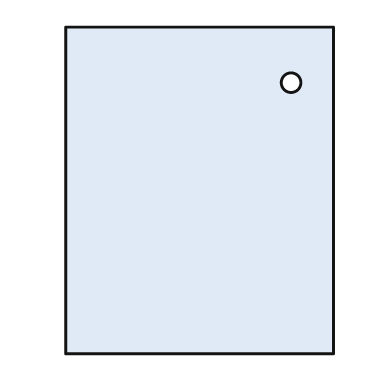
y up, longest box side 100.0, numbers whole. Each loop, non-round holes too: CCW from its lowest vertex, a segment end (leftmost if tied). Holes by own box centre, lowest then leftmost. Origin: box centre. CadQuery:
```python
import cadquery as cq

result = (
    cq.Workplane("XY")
    .moveTo(-41.0, -50.0)
    .lineTo(41.0, -50.0)
    .lineTo(41.0, 50.0)
    .lineTo(-41.0, 50.0)
    .close()
    .moveTo(28.0, 33.0)
    .circle(3.0)
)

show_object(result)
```